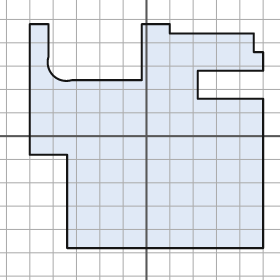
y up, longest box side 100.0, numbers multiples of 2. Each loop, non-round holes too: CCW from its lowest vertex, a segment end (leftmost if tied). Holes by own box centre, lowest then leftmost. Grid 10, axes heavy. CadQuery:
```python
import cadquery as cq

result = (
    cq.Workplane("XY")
    .moveTo(-34.0, -48.0)
    .lineTo(50.0, -48.0)
    .lineTo(50.0, 16.0)
    .lineTo(22.0, 16.0)
    .lineTo(22.0, 28.0)
    .lineTo(50.0, 28.0)
    .lineTo(50.0, 36.0)
    .lineTo(46.0, 36.0)
    .lineTo(46.0, 44.0)
    .lineTo(10.0, 44.0)
    .lineTo(10.0, 48.0)
    .lineTo(-2.0, 48.0)
    .lineTo(-2.0, 24.0)
    .lineTo(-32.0, 24.0)
    .threePointArc((-40.0, 26.0), (-42.0, 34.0))
    .lineTo(-42.0, 48.0)
    .lineTo(-50.0, 48.0)
    .lineTo(-50.0, -8.0)
    .lineTo(-34.0, -8.0)
    .close()
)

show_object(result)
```